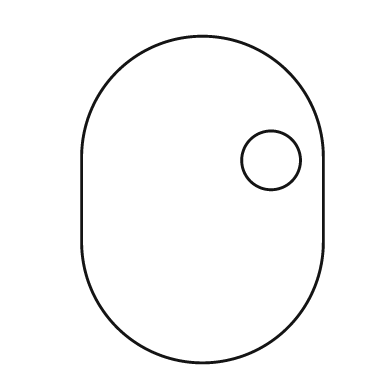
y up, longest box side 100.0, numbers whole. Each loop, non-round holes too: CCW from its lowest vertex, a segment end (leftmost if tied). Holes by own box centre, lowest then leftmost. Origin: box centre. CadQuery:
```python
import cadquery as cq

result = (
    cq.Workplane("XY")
    .moveTo(-37.0, -13.0)
    .threePointArc((0.0, -50.0), (37.0, -13.0))
    .lineTo(37.0, 13.0)
    .threePointArc((0.0, 50.0), (-37.0, 13.0))
    .close()
    .moveTo(21.0, 12.0)
    .circle(9.0)
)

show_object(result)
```